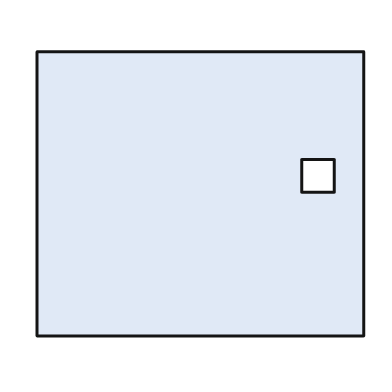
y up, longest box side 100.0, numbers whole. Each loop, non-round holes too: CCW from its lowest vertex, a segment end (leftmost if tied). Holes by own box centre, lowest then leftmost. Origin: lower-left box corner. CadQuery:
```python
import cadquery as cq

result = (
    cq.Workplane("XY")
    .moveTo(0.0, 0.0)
    .lineTo(100.0, 0.0)
    .lineTo(100.0, 87.0)
    .lineTo(0.0, 87.0)
    .close()
    .moveTo(81.0, 44.0)
    .lineTo(91.0, 44.0)
    .lineTo(91.0, 54.0)
    .lineTo(81.0, 54.0)
    .close()
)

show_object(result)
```